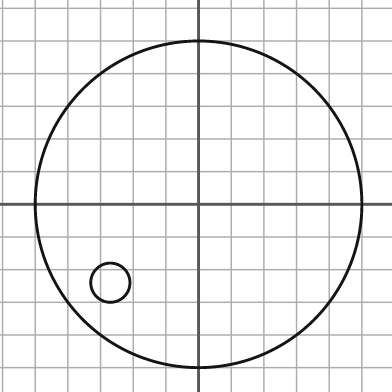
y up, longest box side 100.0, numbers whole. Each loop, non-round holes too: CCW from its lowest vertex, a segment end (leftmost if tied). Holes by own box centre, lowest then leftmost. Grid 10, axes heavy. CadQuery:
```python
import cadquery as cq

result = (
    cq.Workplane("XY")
    .moveTo(0.0, 0.0)
    .circle(50.0)
    .moveTo(-27.0, -24.0)
    .circle(6.0)
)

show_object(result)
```